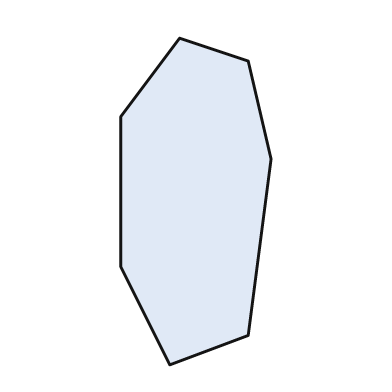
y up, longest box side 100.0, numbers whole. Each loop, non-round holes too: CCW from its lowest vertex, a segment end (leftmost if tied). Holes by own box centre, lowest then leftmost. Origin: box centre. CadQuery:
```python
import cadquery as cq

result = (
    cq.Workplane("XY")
    .moveTo(-8.0, -50.0)
    .lineTo(16.0, -41.0)
    .lineTo(23.0, 13.0)
    .lineTo(16.0, 43.0)
    .lineTo(-5.0, 50.0)
    .lineTo(-23.0, 26.0)
    .lineTo(-23.0, -20.0)
    .close()
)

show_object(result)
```